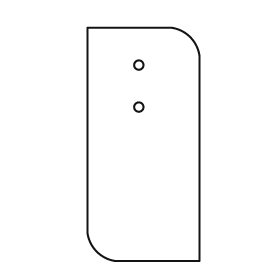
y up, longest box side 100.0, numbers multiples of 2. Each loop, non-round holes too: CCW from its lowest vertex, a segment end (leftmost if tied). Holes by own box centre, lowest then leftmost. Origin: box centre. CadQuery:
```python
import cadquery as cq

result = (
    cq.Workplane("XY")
    .moveTo(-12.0, -50.0)
    .lineTo(24.0, -50.0)
    .lineTo(24.0, 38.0)
    .threePointArc((20.0, 46.0), (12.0, 50.0))
    .lineTo(-24.0, 50.0)
    .lineTo(-24.0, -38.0)
    .threePointArc((-20.0, -46.0), (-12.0, -50.0))
    .close()
    .moveTo(-2.0, 16.0)
    .circle(2.0)
    .moveTo(-2.0, 34.0)
    .circle(2.0)
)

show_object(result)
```